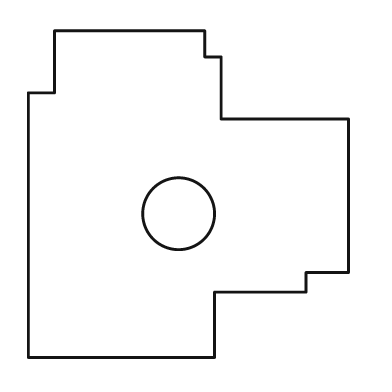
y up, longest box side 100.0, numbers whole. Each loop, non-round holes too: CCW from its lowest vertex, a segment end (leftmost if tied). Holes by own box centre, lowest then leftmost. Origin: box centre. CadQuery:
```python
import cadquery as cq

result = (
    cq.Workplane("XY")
    .moveTo(-49.0, -50.0)
    .lineTo(8.0, -50.0)
    .lineTo(8.0, -30.0)
    .lineTo(36.0, -30.0)
    .lineTo(36.0, -24.0)
    .lineTo(49.0, -24.0)
    .lineTo(49.0, 23.0)
    .lineTo(10.0, 23.0)
    .lineTo(10.0, 42.0)
    .lineTo(5.0, 42.0)
    .lineTo(5.0, 50.0)
    .lineTo(-41.0, 50.0)
    .lineTo(-41.0, 31.0)
    .lineTo(-49.0, 31.0)
    .close()
    .moveTo(-3.0, -6.0)
    .circle(11.0)
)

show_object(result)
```